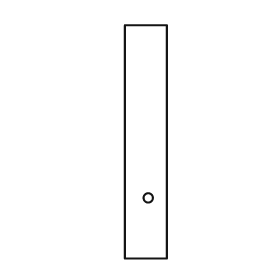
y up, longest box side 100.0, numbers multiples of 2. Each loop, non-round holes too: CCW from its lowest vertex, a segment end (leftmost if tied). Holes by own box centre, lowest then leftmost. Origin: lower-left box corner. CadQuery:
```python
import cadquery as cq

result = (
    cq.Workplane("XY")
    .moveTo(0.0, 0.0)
    .lineTo(18.0, 0.0)
    .lineTo(18.0, 100.0)
    .lineTo(0.0, 100.0)
    .close()
    .moveTo(10.0, 26.0)
    .circle(2.0)
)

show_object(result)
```